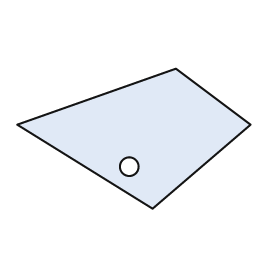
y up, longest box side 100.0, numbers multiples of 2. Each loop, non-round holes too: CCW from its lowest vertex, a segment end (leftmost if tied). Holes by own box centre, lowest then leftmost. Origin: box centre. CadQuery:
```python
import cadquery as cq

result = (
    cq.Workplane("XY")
    .moveTo(8.0, -30.0)
    .lineTo(50.0, 6.0)
    .lineTo(18.0, 30.0)
    .lineTo(-50.0, 6.0)
    .close()
    .moveTo(-2.0, -12.0)
    .circle(4.0)
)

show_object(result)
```